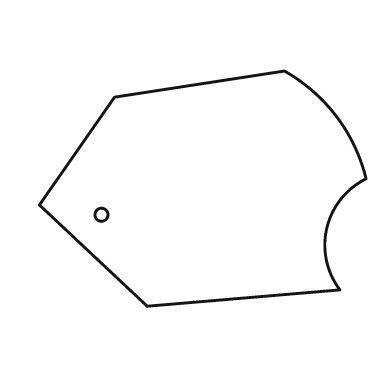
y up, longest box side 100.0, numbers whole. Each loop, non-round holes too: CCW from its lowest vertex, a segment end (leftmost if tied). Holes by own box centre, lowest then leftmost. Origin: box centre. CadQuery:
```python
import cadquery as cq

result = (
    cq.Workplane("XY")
    .moveTo(-17.0, -36.0)
    .lineTo(42.0, -31.0)
    .threePointArc((38.0, -12.0), (50.0, 3.0))
    .threePointArc((41.0, 22.0), (25.0, 36.0))
    .lineTo(-27.0, 28.0)
    .lineTo(-50.0, -5.0)
    .close()
    .moveTo(-31.0, -8.0)
    .circle(2.0)
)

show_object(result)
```